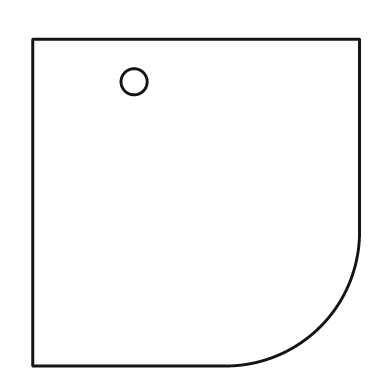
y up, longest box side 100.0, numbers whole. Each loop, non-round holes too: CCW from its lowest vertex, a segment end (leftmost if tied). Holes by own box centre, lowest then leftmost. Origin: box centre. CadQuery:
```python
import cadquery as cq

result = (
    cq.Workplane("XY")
    .moveTo(-50.0, -50.0)
    .lineTo(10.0, -50.0)
    .threePointArc((38.0, -38.0), (50.0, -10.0))
    .lineTo(50.0, 50.0)
    .lineTo(-50.0, 50.0)
    .close()
    .moveTo(-19.0, 37.0)
    .circle(4.0)
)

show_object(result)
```